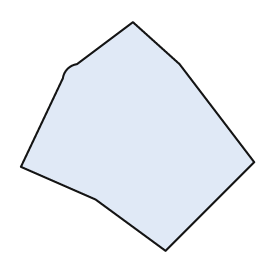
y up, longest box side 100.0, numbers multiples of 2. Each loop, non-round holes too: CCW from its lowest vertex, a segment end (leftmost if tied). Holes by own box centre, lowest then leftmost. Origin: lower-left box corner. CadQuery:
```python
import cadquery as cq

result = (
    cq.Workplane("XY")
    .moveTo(62.0, 0.0)
    .lineTo(100.0, 38.0)
    .lineTo(68.0, 80.0)
    .lineTo(48.0, 98.0)
    .lineTo(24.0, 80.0)
    .threePointArc((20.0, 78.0), (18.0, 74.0))
    .lineTo(0.0, 36.0)
    .lineTo(32.0, 22.0)
    .close()
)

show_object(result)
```